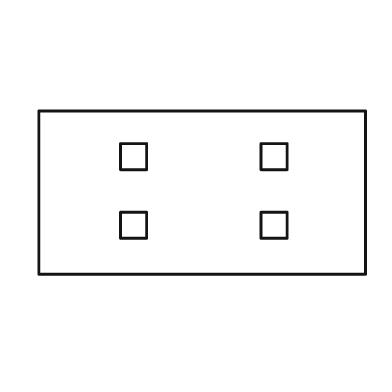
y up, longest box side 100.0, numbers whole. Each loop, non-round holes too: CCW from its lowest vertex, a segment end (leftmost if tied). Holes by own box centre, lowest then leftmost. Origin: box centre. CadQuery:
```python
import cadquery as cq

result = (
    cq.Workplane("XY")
    .moveTo(-50.0, -25.0)
    .lineTo(50.0, -25.0)
    .lineTo(50.0, 25.0)
    .lineTo(-50.0, 25.0)
    .close()
    .moveTo(-25.0, -14.0)
    .lineTo(-17.0, -14.0)
    .lineTo(-17.0, -6.0)
    .lineTo(-25.0, -6.0)
    .close()
    .moveTo(18.0, -14.0)
    .lineTo(26.0, -14.0)
    .lineTo(26.0, -6.0)
    .lineTo(18.0, -6.0)
    .close()
    .moveTo(-25.0, 7.0)
    .lineTo(-17.0, 7.0)
    .lineTo(-17.0, 15.0)
    .lineTo(-25.0, 15.0)
    .close()
    .moveTo(18.0, 7.0)
    .lineTo(26.0, 7.0)
    .lineTo(26.0, 15.0)
    .lineTo(18.0, 15.0)
    .close()
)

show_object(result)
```